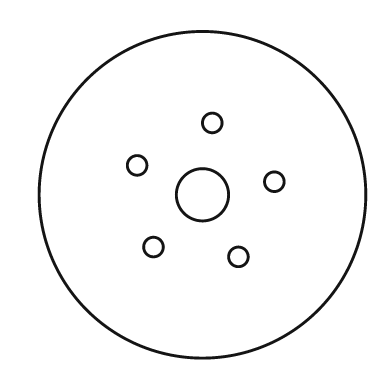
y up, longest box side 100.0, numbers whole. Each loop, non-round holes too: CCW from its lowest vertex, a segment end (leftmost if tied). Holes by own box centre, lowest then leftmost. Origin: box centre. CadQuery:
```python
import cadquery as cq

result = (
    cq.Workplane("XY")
    .moveTo(0.0, 0.0)
    .circle(50.0)
    .moveTo(11.0, -19.0)
    .circle(3.0)
    .moveTo(-15.0, -16.0)
    .circle(3.0)
    .moveTo(0.0, 0.0)
    .circle(8.0)
    .moveTo(22.0, 4.0)
    .circle(3.0)
    .moveTo(-20.0, 9.0)
    .circle(3.0)
    .moveTo(3.0, 22.0)
    .circle(3.0)
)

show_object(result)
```